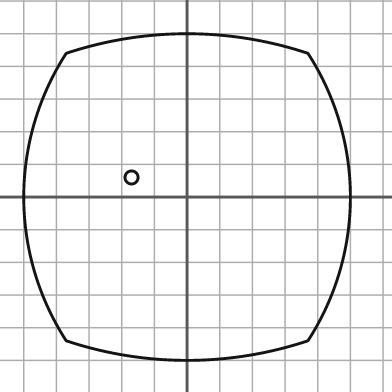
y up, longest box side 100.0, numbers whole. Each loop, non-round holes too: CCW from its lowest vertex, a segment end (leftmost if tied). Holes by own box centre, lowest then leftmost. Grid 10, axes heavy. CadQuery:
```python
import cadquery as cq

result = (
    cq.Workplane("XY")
    .moveTo(-37.0, -44.0)
    .threePointArc((0.0, -50.0), (37.0, -44.0))
    .threePointArc((50.0, 0.0), (37.0, 44.0))
    .threePointArc((0.0, 50.0), (-37.0, 44.0))
    .threePointArc((-50.0, 0.0), (-37.0, -44.0))
    .close()
    .moveTo(-17.0, 6.0)
    .circle(2.0)
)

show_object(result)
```